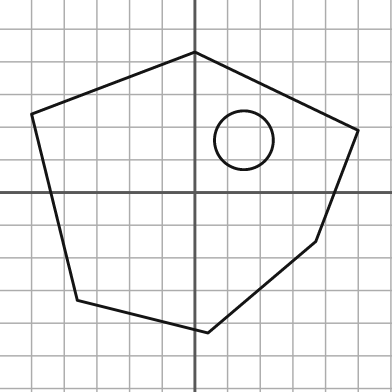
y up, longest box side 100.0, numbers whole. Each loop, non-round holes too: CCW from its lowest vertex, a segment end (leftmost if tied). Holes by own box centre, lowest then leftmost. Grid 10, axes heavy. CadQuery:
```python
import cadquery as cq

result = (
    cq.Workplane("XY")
    .moveTo(4.0, -43.0)
    .lineTo(37.0, -15.0)
    .lineTo(50.0, 19.0)
    .lineTo(0.0, 43.0)
    .lineTo(-50.0, 24.0)
    .lineTo(-36.0, -33.0)
    .close()
    .moveTo(15.0, 16.0)
    .circle(9.0)
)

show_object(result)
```